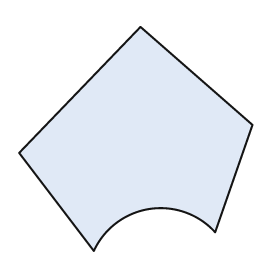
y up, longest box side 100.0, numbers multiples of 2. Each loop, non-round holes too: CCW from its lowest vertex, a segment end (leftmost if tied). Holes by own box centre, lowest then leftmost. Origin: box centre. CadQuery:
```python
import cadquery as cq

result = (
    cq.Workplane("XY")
    .moveTo(-18.0, -48.0)
    .threePointArc((6.0, -30.0), (34.0, -40.0))
    .lineTo(50.0, 6.0)
    .lineTo(2.0, 48.0)
    .lineTo(-50.0, -6.0)
    .close()
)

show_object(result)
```